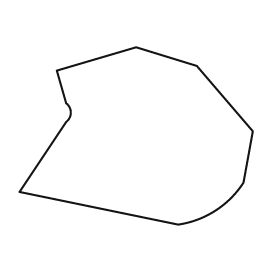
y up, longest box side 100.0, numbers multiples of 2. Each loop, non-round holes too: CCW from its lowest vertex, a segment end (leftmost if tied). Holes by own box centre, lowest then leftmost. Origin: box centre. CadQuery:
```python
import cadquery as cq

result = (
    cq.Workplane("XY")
    .moveTo(18.0, -38.0)
    .threePointArc((34.0, -32.0), (46.0, -20.0))
    .lineTo(50.0, 2.0)
    .lineTo(26.0, 30.0)
    .lineTo(0.0, 38.0)
    .lineTo(-34.0, 28.0)
    .lineTo(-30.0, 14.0)
    .threePointArc((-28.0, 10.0), (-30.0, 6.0))
    .lineTo(-50.0, -24.0)
    .close()
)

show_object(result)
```